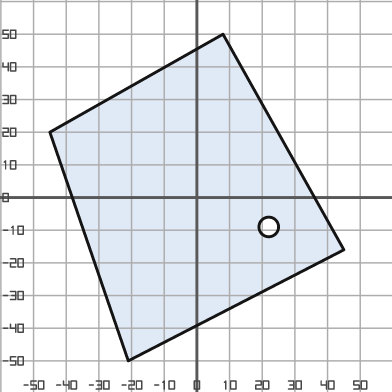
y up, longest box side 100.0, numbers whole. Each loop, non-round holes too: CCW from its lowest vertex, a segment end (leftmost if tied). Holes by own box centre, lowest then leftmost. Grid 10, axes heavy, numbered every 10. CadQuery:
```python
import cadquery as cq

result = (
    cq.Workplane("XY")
    .moveTo(-21.0, -50.0)
    .lineTo(45.0, -16.0)
    .lineTo(8.0, 50.0)
    .lineTo(-45.0, 20.0)
    .close()
    .moveTo(22.0, -9.0)
    .circle(3.0)
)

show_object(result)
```